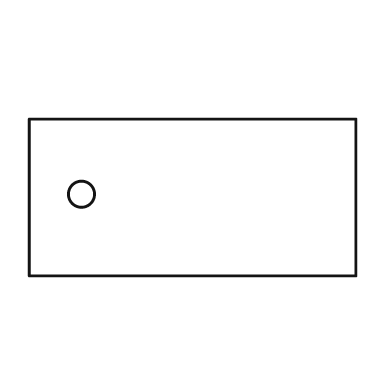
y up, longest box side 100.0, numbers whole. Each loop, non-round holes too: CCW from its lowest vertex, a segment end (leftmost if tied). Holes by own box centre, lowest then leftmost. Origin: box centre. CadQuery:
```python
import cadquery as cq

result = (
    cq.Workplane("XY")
    .moveTo(-50.0, -24.0)
    .lineTo(50.0, -24.0)
    .lineTo(50.0, 24.0)
    .lineTo(-50.0, 24.0)
    .close()
    .moveTo(-34.0, 1.0)
    .circle(4.0)
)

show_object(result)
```